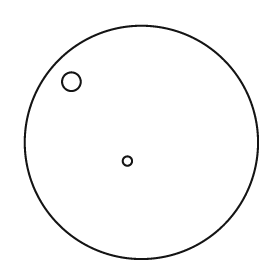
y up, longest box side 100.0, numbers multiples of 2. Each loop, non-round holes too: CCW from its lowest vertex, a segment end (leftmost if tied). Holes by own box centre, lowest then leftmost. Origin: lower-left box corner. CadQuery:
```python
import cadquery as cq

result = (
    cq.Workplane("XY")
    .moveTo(50.0, 50.0)
    .circle(50.0)
    .moveTo(44.0, 42.0)
    .circle(2.0)
    .moveTo(20.0, 76.0)
    .circle(4.0)
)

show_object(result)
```